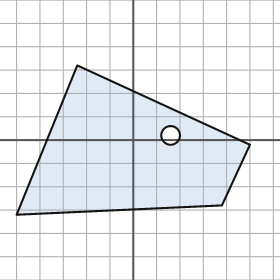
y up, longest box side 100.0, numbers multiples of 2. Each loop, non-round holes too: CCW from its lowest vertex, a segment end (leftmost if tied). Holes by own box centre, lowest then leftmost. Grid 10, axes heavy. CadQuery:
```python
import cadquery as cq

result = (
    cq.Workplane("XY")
    .moveTo(-50.0, -32.0)
    .lineTo(38.0, -28.0)
    .lineTo(50.0, -2.0)
    .lineTo(-24.0, 32.0)
    .close()
    .moveTo(16.0, 2.0)
    .circle(4.0)
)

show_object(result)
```